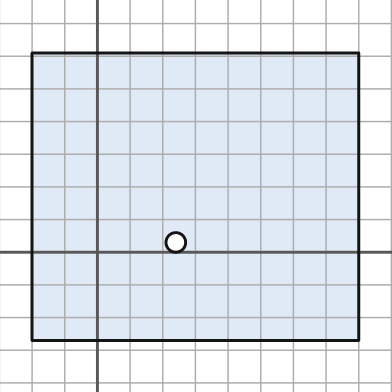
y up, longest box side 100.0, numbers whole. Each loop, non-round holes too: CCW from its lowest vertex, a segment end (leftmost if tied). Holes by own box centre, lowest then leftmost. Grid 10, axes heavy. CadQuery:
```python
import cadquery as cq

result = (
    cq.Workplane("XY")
    .moveTo(-20.0, -27.0)
    .lineTo(80.0, -27.0)
    .lineTo(80.0, 61.0)
    .lineTo(-20.0, 61.0)
    .close()
    .moveTo(24.0, 3.0)
    .circle(3.0)
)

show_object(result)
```